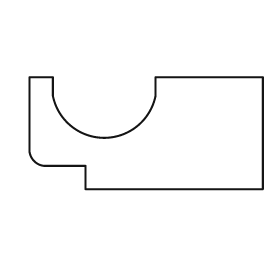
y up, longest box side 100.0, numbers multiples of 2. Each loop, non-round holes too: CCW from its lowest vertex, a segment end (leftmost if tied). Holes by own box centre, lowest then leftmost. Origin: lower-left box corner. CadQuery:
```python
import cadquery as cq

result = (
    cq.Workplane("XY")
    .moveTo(24.0, 0.0)
    .lineTo(100.0, 0.0)
    .lineTo(100.0, 48.0)
    .lineTo(54.0, 48.0)
    .lineTo(54.0, 40.0)
    .threePointArc((32.0, 22.0), (10.0, 40.0))
    .lineTo(10.0, 48.0)
    .lineTo(0.0, 48.0)
    .lineTo(0.0, 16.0)
    .threePointArc((2.0, 12.0), (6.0, 10.0))
    .lineTo(24.0, 10.0)
    .close()
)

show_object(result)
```